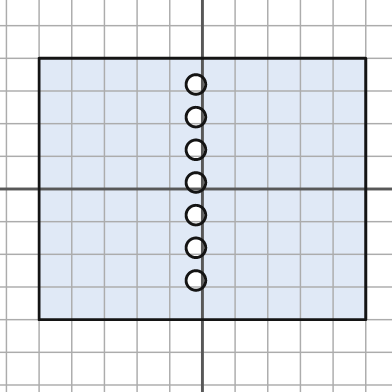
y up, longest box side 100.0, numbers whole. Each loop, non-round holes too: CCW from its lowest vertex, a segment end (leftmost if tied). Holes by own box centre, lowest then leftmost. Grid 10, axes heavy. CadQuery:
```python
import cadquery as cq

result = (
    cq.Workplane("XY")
    .moveTo(-50.0, -40.0)
    .lineTo(50.0, -40.0)
    .lineTo(50.0, 40.0)
    .lineTo(-50.0, 40.0)
    .close()
    .moveTo(-2.0, -28.0)
    .circle(3.0)
    .moveTo(-2.0, -18.0)
    .circle(3.0)
    .moveTo(-2.0, -8.0)
    .circle(3.0)
    .moveTo(-2.0, 2.0)
    .circle(3.0)
    .moveTo(-2.0, 12.0)
    .circle(3.0)
    .moveTo(-2.0, 22.0)
    .circle(3.0)
    .moveTo(-2.0, 32.0)
    .circle(3.0)
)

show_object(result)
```